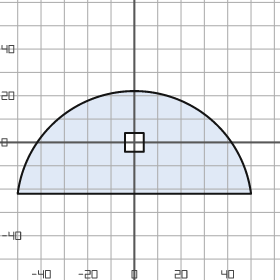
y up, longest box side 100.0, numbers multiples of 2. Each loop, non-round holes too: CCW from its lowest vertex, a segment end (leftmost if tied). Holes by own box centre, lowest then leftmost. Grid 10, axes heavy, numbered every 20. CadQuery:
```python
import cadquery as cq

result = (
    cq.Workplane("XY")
    .moveTo(-50.0, -22.0)
    .lineTo(50.0, -22.0)
    .threePointArc((0.0, 22.0), (-50.0, -22.0))
    .close()
    .moveTo(-4.0, -4.0)
    .lineTo(4.0, -4.0)
    .lineTo(4.0, 4.0)
    .lineTo(-4.0, 4.0)
    .close()
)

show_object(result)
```